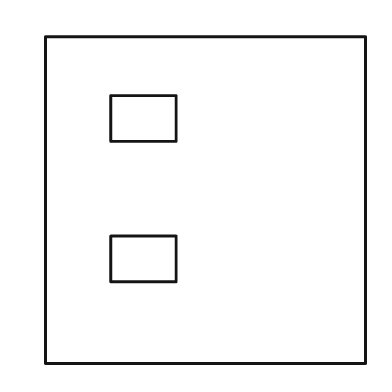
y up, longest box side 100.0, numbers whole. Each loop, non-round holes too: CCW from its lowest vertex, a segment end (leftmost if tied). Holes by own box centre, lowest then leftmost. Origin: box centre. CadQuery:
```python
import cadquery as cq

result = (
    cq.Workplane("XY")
    .moveTo(-49.0, -50.0)
    .lineTo(49.0, -50.0)
    .lineTo(49.0, 50.0)
    .lineTo(-49.0, 50.0)
    .close()
    .moveTo(-29.0, -25.0)
    .lineTo(-9.0, -25.0)
    .lineTo(-9.0, -11.0)
    .lineTo(-29.0, -11.0)
    .close()
    .moveTo(-29.0, 18.0)
    .lineTo(-9.0, 18.0)
    .lineTo(-9.0, 32.0)
    .lineTo(-29.0, 32.0)
    .close()
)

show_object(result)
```